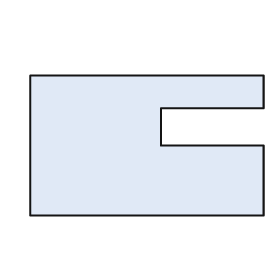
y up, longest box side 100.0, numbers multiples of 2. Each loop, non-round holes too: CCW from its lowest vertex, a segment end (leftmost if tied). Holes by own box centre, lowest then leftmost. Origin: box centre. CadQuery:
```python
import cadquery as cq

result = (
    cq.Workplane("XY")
    .moveTo(-50.0, -30.0)
    .lineTo(50.0, -30.0)
    .lineTo(50.0, 0.0)
    .lineTo(6.0, 0.0)
    .lineTo(6.0, 16.0)
    .lineTo(50.0, 16.0)
    .lineTo(50.0, 30.0)
    .lineTo(-50.0, 30.0)
    .close()
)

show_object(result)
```